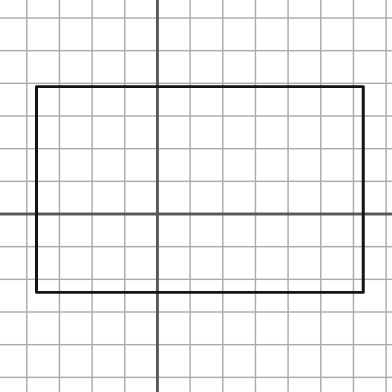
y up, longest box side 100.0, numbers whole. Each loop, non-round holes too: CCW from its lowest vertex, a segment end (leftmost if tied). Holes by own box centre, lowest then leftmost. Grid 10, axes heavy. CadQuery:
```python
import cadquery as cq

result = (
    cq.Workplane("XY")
    .moveTo(-37.0, -24.0)
    .lineTo(63.0, -24.0)
    .lineTo(63.0, 39.0)
    .lineTo(-37.0, 39.0)
    .close()
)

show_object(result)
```